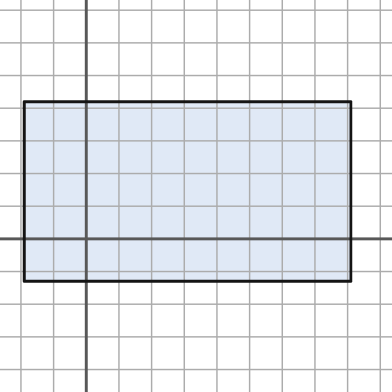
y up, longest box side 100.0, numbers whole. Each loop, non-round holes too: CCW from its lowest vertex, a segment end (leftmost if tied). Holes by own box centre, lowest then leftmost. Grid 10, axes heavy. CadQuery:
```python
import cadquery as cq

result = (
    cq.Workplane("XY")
    .moveTo(-19.0, -13.0)
    .lineTo(81.0, -13.0)
    .lineTo(81.0, 42.0)
    .lineTo(-19.0, 42.0)
    .close()
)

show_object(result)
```